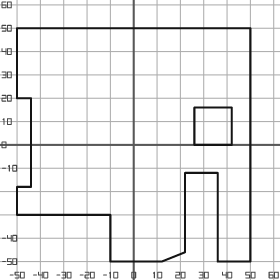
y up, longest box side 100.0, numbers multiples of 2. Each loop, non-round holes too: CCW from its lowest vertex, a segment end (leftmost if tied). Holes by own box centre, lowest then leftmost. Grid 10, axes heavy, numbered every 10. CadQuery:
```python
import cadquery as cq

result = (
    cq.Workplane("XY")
    .moveTo(-10.0, -50.0)
    .lineTo(12.0, -50.0)
    .lineTo(22.0, -46.0)
    .lineTo(22.0, -12.0)
    .lineTo(36.0, -12.0)
    .lineTo(36.0, -50.0)
    .lineTo(50.0, -50.0)
    .lineTo(50.0, 50.0)
    .lineTo(-50.0, 50.0)
    .lineTo(-50.0, 20.0)
    .lineTo(-44.0, 20.0)
    .lineTo(-44.0, -18.0)
    .lineTo(-50.0, -18.0)
    .lineTo(-50.0, -30.0)
    .lineTo(-10.0, -30.0)
    .close()
    .moveTo(26.0, 0.0)
    .lineTo(42.0, 0.0)
    .lineTo(42.0, 16.0)
    .lineTo(26.0, 16.0)
    .close()
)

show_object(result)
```